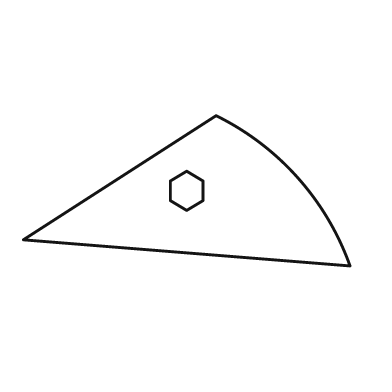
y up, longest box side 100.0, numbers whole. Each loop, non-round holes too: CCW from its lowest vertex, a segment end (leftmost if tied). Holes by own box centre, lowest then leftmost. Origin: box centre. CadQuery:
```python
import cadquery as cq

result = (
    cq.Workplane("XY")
    .moveTo(50.0, -23.0)
    .threePointArc((34.0, 4.0), (9.0, 23.0))
    .lineTo(-50.0, -15.0)
    .close()
    .moveTo(0.0, -6.0)
    .lineTo(5.0, -3.0)
    .lineTo(5.0, 3.0)
    .lineTo(0.0, 6.0)
    .lineTo(-5.0, 3.0)
    .lineTo(-5.0, -3.0)
    .close()
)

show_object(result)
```